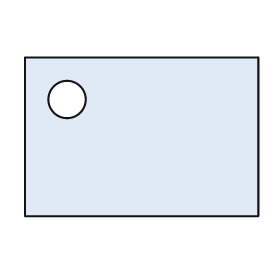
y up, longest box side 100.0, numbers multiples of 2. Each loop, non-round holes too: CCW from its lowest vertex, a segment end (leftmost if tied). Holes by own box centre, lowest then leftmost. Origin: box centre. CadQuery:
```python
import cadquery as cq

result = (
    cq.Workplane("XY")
    .moveTo(-50.0, -34.0)
    .lineTo(50.0, -34.0)
    .lineTo(50.0, 34.0)
    .lineTo(-50.0, 34.0)
    .close()
    .moveTo(-32.0, 16.0)
    .circle(8.0)
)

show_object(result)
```